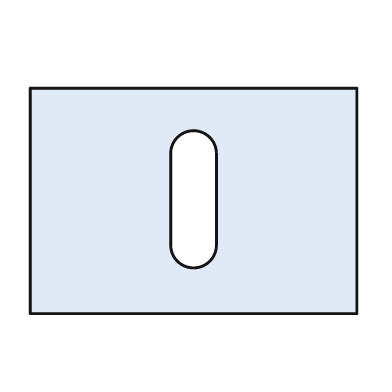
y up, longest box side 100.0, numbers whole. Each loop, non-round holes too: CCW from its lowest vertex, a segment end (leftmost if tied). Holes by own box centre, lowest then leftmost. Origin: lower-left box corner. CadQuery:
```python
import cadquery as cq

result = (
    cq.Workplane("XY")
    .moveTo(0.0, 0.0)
    .lineTo(100.0, 0.0)
    .lineTo(100.0, 69.0)
    .lineTo(0.0, 69.0)
    .close()
    .moveTo(43.0, 21.0)
    .threePointArc((50.0, 14.0), (57.0, 21.0))
    .lineTo(57.0, 49.0)
    .threePointArc((50.0, 56.0), (43.0, 49.0))
    .close()
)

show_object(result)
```